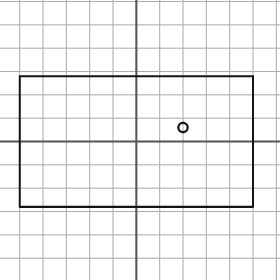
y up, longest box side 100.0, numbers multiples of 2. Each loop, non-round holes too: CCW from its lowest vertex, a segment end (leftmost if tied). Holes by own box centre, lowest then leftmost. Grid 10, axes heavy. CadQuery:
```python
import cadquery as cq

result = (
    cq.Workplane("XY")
    .moveTo(-50.0, -28.0)
    .lineTo(50.0, -28.0)
    .lineTo(50.0, 28.0)
    .lineTo(-50.0, 28.0)
    .close()
    .moveTo(20.0, 6.0)
    .circle(2.0)
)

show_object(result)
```